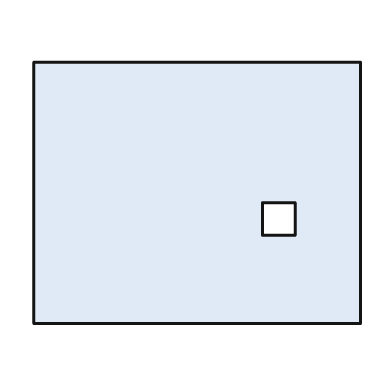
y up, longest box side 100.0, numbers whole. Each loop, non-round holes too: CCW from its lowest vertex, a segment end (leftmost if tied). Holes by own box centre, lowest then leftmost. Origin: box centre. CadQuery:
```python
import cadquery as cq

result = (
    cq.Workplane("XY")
    .moveTo(-50.0, -40.0)
    .lineTo(50.0, -40.0)
    .lineTo(50.0, 40.0)
    .lineTo(-50.0, 40.0)
    .close()
    .moveTo(20.0, -13.0)
    .lineTo(30.0, -13.0)
    .lineTo(30.0, -3.0)
    .lineTo(20.0, -3.0)
    .close()
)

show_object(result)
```